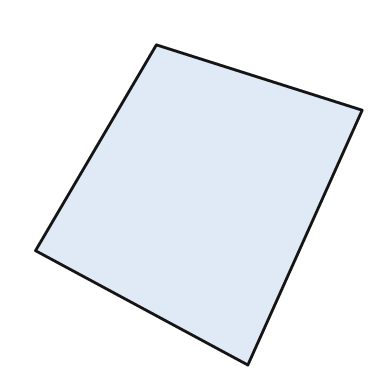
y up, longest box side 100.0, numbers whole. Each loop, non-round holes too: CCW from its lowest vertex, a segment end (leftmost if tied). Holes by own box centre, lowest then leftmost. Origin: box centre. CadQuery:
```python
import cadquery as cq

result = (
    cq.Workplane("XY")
    .moveTo(15.0, -49.0)
    .lineTo(50.0, 29.0)
    .lineTo(-13.0, 49.0)
    .lineTo(-50.0, -14.0)
    .close()
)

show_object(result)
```